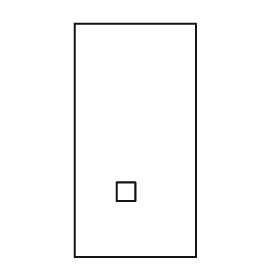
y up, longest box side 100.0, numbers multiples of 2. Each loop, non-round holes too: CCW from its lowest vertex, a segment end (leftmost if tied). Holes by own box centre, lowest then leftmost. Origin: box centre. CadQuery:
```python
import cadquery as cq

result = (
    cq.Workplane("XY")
    .moveTo(-26.0, -50.0)
    .lineTo(26.0, -50.0)
    .lineTo(26.0, 50.0)
    .lineTo(-26.0, 50.0)
    .close()
    .moveTo(-8.0, -26.0)
    .lineTo(0.0, -26.0)
    .lineTo(0.0, -18.0)
    .lineTo(-8.0, -18.0)
    .close()
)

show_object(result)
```